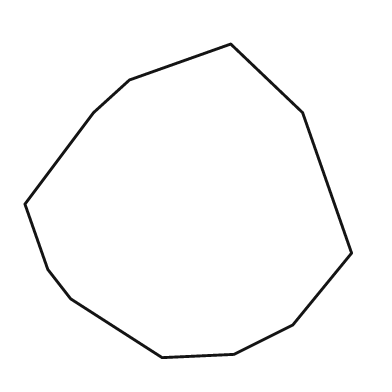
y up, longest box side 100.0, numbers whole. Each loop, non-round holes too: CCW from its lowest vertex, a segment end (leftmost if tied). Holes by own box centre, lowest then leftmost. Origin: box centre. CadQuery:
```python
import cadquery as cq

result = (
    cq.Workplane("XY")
    .moveTo(-8.0, -48.0)
    .lineTo(14.0, -47.0)
    .lineTo(32.0, -38.0)
    .lineTo(50.0, -16.0)
    .lineTo(35.0, 27.0)
    .lineTo(13.0, 48.0)
    .lineTo(-18.0, 37.0)
    .lineTo(-29.0, 27.0)
    .lineTo(-50.0, -1.0)
    .lineTo(-43.0, -21.0)
    .lineTo(-36.0, -30.0)
    .close()
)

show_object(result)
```